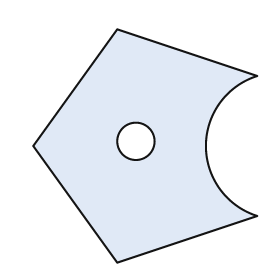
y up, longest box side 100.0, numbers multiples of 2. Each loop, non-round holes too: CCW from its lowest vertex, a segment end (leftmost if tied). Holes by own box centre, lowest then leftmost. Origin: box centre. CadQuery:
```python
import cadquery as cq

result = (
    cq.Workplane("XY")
    .moveTo(-12.0, -50.0)
    .lineTo(48.0, -30.0)
    .threePointArc((26.0, 0.0), (48.0, 30.0))
    .lineTo(-12.0, 50.0)
    .lineTo(-48.0, 0.0)
    .close()
    .moveTo(-4.0, 2.0)
    .circle(8.0)
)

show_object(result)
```